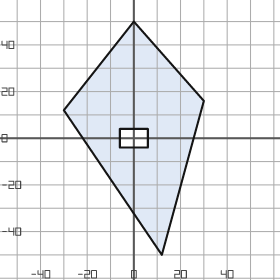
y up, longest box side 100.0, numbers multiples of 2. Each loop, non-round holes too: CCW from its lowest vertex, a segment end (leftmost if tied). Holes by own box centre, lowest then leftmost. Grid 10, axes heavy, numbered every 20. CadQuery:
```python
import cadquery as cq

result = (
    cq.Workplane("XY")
    .moveTo(12.0, -50.0)
    .lineTo(30.0, 16.0)
    .lineTo(0.0, 50.0)
    .lineTo(-30.0, 12.0)
    .close()
    .moveTo(-6.0, -4.0)
    .lineTo(6.0, -4.0)
    .lineTo(6.0, 4.0)
    .lineTo(-6.0, 4.0)
    .close()
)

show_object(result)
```